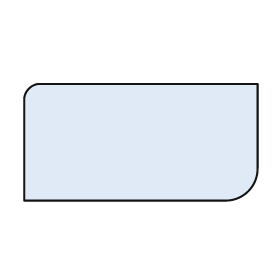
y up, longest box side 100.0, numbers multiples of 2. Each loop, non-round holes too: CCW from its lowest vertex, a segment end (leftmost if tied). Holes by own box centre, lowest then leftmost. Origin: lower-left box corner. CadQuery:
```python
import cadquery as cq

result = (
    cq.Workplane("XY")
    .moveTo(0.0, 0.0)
    .lineTo(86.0, 0.0)
    .threePointArc((96.0, 4.0), (100.0, 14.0))
    .lineTo(100.0, 50.0)
    .lineTo(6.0, 50.0)
    .threePointArc((2.0, 48.0), (0.0, 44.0))
    .close()
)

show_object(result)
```